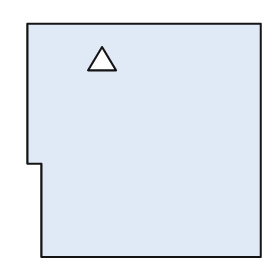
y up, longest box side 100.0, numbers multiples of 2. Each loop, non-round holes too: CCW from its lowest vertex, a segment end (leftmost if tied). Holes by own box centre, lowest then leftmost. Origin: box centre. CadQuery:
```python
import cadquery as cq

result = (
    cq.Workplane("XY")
    .moveTo(-44.0, -50.0)
    .lineTo(50.0, -50.0)
    .lineTo(50.0, 50.0)
    .lineTo(-50.0, 50.0)
    .lineTo(-50.0, -10.0)
    .lineTo(-44.0, -10.0)
    .close()
    .moveTo(-24.0, 30.0)
    .lineTo(-12.0, 30.0)
    .lineTo(-18.0, 40.0)
    .close()
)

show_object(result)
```